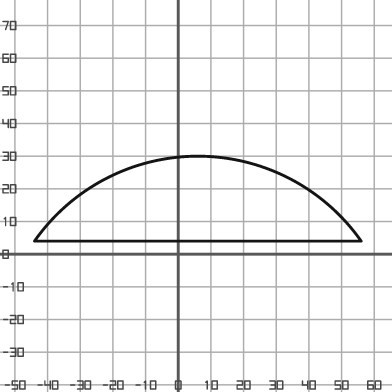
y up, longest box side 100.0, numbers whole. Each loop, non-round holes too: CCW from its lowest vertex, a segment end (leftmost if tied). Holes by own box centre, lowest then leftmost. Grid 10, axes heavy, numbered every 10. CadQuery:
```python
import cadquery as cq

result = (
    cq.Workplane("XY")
    .moveTo(-44.0, 4.0)
    .lineTo(56.0, 4.0)
    .threePointArc((6.0, 30.0), (-44.0, 4.0))
    .close()
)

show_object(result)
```